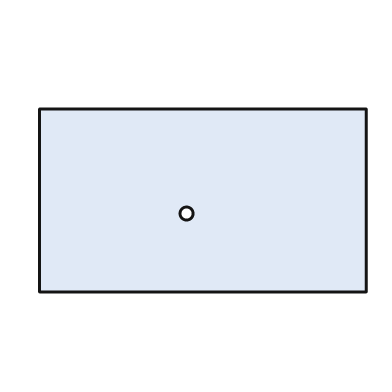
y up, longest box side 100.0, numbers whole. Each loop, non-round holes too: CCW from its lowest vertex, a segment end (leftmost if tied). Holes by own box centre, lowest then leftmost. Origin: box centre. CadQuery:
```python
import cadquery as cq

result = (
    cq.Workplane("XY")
    .moveTo(-50.0, -28.0)
    .lineTo(50.0, -28.0)
    .lineTo(50.0, 28.0)
    .lineTo(-50.0, 28.0)
    .close()
    .moveTo(-5.0, -4.0)
    .circle(2.0)
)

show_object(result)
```